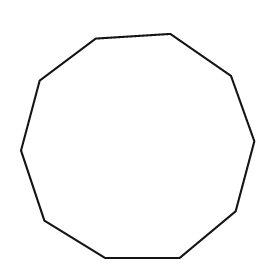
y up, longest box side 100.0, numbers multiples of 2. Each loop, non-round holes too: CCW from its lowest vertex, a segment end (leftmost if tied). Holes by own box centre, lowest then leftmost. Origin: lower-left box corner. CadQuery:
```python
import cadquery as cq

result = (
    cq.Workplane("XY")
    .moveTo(36.0, 0.0)
    .lineTo(68.0, 0.0)
    .lineTo(92.0, 20.0)
    .lineTo(100.0, 50.0)
    .lineTo(90.0, 78.0)
    .lineTo(64.0, 96.0)
    .lineTo(32.0, 94.0)
    .lineTo(8.0, 76.0)
    .lineTo(0.0, 46.0)
    .lineTo(10.0, 16.0)
    .close()
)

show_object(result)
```